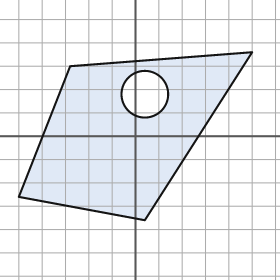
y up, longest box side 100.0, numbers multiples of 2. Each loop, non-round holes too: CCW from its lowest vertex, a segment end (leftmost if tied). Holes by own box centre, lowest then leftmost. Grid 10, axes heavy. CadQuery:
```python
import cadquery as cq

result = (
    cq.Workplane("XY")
    .moveTo(4.0, -36.0)
    .lineTo(50.0, 36.0)
    .lineTo(-28.0, 30.0)
    .lineTo(-50.0, -26.0)
    .close()
    .moveTo(4.0, 18.0)
    .circle(10.0)
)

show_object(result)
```